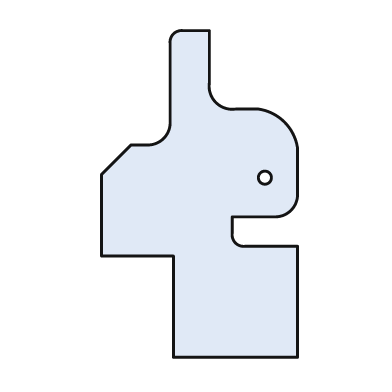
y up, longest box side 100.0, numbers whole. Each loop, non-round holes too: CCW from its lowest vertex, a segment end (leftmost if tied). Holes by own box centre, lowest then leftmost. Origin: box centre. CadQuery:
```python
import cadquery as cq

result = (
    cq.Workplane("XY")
    .moveTo(-8.0, -50.0)
    .lineTo(30.0, -50.0)
    .lineTo(30.0, -16.0)
    .lineTo(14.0, -16.0)
    .threePointArc((11.0, -15.0), (10.0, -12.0))
    .lineTo(10.0, -7.0)
    .lineTo(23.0, -7.0)
    .threePointArc((28.0, -5.0), (30.0, 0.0))
    .lineTo(30.0, 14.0)
    .threePointArc((26.0, 22.0), (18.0, 26.0))
    .lineTo(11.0, 26.0)
    .threePointArc((5.0, 28.0), (3.0, 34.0))
    .lineTo(3.0, 50.0)
    .lineTo(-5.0, 50.0)
    .threePointArc((-8.0, 49.0), (-9.0, 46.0))
    .lineTo(-9.0, 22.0)
    .threePointArc((-11.0, 17.0), (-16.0, 15.0))
    .lineTo(-21.0, 15.0)
    .lineTo(-30.0, 6.0)
    .lineTo(-30.0, -19.0)
    .lineTo(-8.0, -19.0)
    .close()
    .moveTo(20.0, 5.0)
    .circle(2.0)
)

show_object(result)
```